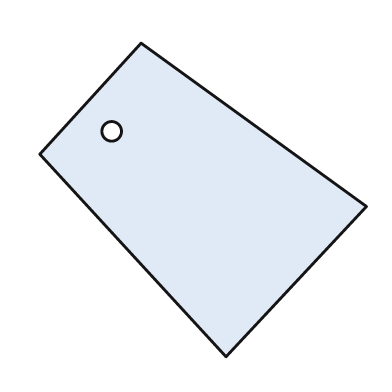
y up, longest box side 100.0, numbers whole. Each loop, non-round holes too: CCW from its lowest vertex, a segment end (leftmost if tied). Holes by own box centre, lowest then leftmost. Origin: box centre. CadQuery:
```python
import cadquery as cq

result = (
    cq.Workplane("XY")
    .moveTo(7.0, -48.0)
    .lineTo(50.0, -2.0)
    .lineTo(-19.0, 48.0)
    .lineTo(-50.0, 14.0)
    .close()
    .moveTo(-28.0, 21.0)
    .circle(3.0)
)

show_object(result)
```